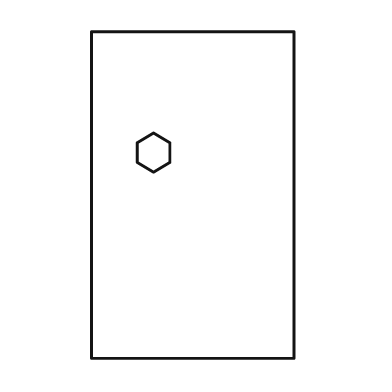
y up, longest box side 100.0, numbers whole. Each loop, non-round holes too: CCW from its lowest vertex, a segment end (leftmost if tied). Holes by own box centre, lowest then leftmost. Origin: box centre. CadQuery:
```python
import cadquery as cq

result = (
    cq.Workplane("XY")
    .moveTo(-31.0, -50.0)
    .lineTo(31.0, -50.0)
    .lineTo(31.0, 50.0)
    .lineTo(-31.0, 50.0)
    .close()
    .moveTo(-12.0, 7.0)
    .lineTo(-7.0, 10.0)
    .lineTo(-7.0, 16.0)
    .lineTo(-12.0, 19.0)
    .lineTo(-17.0, 16.0)
    .lineTo(-17.0, 10.0)
    .close()
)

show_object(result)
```